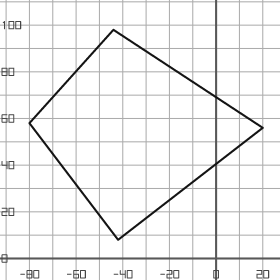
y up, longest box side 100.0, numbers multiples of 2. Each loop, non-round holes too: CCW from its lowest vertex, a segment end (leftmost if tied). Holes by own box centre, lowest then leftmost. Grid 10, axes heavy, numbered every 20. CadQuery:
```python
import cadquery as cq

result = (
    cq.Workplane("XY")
    .moveTo(-42.0, 8.0)
    .lineTo(20.0, 56.0)
    .lineTo(-44.0, 98.0)
    .lineTo(-80.0, 58.0)
    .close()
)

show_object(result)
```